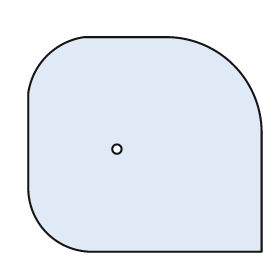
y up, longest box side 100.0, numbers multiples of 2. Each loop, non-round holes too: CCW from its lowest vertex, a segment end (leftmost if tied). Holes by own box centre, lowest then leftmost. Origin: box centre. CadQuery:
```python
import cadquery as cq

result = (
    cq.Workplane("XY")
    .moveTo(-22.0, -46.0)
    .lineTo(50.0, -46.0)
    .lineTo(50.0, 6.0)
    .threePointArc((38.0, 34.0), (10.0, 46.0))
    .lineTo(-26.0, 46.0)
    .threePointArc((-42.0, 38.0), (-50.0, 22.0))
    .lineTo(-50.0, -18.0)
    .threePointArc((-42.0, -38.0), (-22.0, -46.0))
    .close()
    .moveTo(-12.0, -2.0)
    .circle(2.0)
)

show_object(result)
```